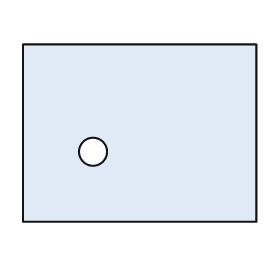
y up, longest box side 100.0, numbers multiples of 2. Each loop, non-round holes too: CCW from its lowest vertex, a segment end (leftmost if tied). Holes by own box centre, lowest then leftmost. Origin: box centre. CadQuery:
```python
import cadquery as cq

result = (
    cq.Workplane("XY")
    .moveTo(-50.0, -38.0)
    .lineTo(50.0, -38.0)
    .lineTo(50.0, 38.0)
    .lineTo(-50.0, 38.0)
    .close()
    .moveTo(-20.0, -8.0)
    .circle(6.0)
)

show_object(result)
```